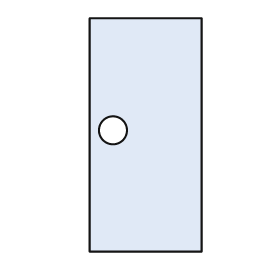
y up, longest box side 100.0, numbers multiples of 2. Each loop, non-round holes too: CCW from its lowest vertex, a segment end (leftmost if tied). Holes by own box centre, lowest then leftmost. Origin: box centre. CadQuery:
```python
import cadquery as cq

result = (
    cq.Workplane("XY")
    .moveTo(-24.0, -50.0)
    .lineTo(24.0, -50.0)
    .lineTo(24.0, 50.0)
    .lineTo(-24.0, 50.0)
    .close()
    .moveTo(-14.0, 2.0)
    .circle(6.0)
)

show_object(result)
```